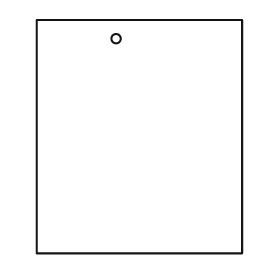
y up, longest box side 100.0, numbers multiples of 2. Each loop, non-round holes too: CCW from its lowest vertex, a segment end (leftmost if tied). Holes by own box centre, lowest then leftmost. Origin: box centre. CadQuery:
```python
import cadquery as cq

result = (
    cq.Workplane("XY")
    .moveTo(-44.0, -50.0)
    .lineTo(44.0, -50.0)
    .lineTo(44.0, 50.0)
    .lineTo(-44.0, 50.0)
    .close()
    .moveTo(-10.0, 42.0)
    .circle(2.0)
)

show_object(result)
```